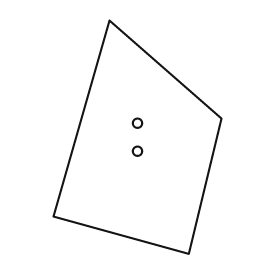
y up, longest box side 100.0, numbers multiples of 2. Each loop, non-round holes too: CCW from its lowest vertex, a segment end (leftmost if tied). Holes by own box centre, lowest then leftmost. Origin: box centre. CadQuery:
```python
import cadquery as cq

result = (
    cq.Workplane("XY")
    .moveTo(22.0, -50.0)
    .lineTo(36.0, 8.0)
    .lineTo(-12.0, 50.0)
    .lineTo(-36.0, -34.0)
    .close()
    .moveTo(0.0, -6.0)
    .circle(2.0)
    .moveTo(0.0, 6.0)
    .circle(2.0)
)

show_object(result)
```